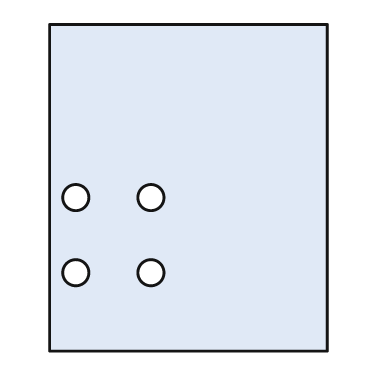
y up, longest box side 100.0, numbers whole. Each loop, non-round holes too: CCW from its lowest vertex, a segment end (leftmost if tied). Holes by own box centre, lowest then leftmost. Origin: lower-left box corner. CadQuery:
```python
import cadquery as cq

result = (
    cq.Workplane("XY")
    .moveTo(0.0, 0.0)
    .lineTo(85.0, 0.0)
    .lineTo(85.0, 100.0)
    .lineTo(0.0, 100.0)
    .close()
    .moveTo(8.0, 24.0)
    .circle(4.0)
    .moveTo(31.0, 24.0)
    .circle(4.0)
    .moveTo(8.0, 47.0)
    .circle(4.0)
    .moveTo(31.0, 47.0)
    .circle(4.0)
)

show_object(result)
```